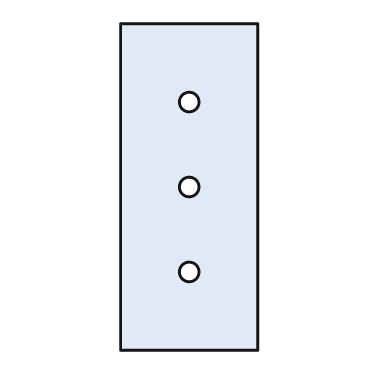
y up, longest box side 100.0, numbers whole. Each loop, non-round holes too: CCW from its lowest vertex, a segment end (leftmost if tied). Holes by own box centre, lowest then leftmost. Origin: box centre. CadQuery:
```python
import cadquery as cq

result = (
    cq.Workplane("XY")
    .moveTo(-21.0, -50.0)
    .lineTo(21.0, -50.0)
    .lineTo(21.0, 50.0)
    .lineTo(-21.0, 50.0)
    .close()
    .moveTo(0.0, -26.0)
    .circle(3.0)
    .moveTo(0.0, 0.0)
    .circle(3.0)
    .moveTo(0.0, 26.0)
    .circle(3.0)
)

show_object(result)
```